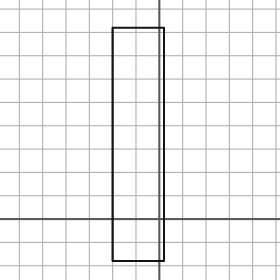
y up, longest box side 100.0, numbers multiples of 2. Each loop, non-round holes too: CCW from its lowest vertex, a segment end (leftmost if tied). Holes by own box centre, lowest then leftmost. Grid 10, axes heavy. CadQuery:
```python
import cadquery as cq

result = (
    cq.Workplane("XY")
    .moveTo(-20.0, -18.0)
    .lineTo(2.0, -18.0)
    .lineTo(2.0, 82.0)
    .lineTo(-20.0, 82.0)
    .close()
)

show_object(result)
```